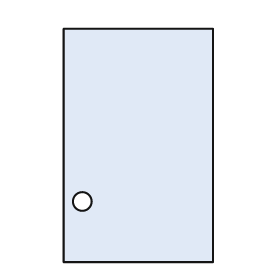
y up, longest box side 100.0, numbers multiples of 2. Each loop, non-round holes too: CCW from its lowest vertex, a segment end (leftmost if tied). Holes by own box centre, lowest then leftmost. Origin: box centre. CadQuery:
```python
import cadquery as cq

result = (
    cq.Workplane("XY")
    .moveTo(-32.0, -50.0)
    .lineTo(32.0, -50.0)
    .lineTo(32.0, 50.0)
    .lineTo(-32.0, 50.0)
    .close()
    .moveTo(-24.0, -24.0)
    .circle(4.0)
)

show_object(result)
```